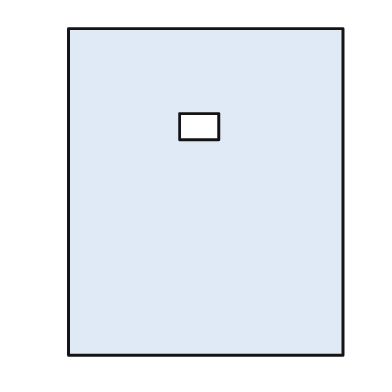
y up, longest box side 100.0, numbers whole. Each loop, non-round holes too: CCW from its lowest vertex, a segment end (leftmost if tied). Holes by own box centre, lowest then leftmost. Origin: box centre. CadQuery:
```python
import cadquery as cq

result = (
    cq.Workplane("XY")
    .moveTo(-42.0, -50.0)
    .lineTo(42.0, -50.0)
    .lineTo(42.0, 50.0)
    .lineTo(-42.0, 50.0)
    .close()
    .moveTo(-8.0, 16.0)
    .lineTo(4.0, 16.0)
    .lineTo(4.0, 24.0)
    .lineTo(-8.0, 24.0)
    .close()
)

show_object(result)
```